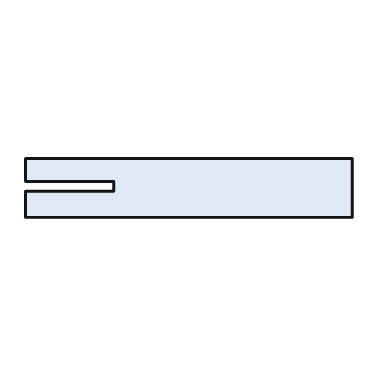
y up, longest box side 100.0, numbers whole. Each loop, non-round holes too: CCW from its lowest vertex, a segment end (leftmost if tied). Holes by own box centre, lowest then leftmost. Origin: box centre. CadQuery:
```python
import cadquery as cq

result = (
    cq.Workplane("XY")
    .moveTo(-50.0, -9.0)
    .lineTo(50.0, -9.0)
    .lineTo(50.0, 9.0)
    .lineTo(-50.0, 9.0)
    .lineTo(-50.0, 2.0)
    .lineTo(-23.0, 2.0)
    .lineTo(-23.0, -1.0)
    .lineTo(-50.0, -1.0)
    .close()
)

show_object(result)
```